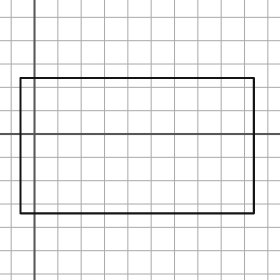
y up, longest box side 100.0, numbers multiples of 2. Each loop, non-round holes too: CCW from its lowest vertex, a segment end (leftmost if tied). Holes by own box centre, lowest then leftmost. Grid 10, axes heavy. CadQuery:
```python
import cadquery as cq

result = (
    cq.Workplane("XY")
    .moveTo(-6.0, -34.0)
    .lineTo(94.0, -34.0)
    .lineTo(94.0, 24.0)
    .lineTo(-6.0, 24.0)
    .close()
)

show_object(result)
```